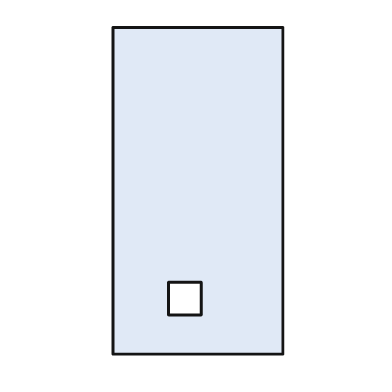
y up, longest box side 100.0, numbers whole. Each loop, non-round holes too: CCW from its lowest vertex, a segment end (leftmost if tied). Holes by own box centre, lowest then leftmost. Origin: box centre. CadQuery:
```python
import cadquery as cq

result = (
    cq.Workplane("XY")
    .moveTo(-26.0, -50.0)
    .lineTo(26.0, -50.0)
    .lineTo(26.0, 50.0)
    .lineTo(-26.0, 50.0)
    .close()
    .moveTo(-9.0, -38.0)
    .lineTo(1.0, -38.0)
    .lineTo(1.0, -28.0)
    .lineTo(-9.0, -28.0)
    .close()
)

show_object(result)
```